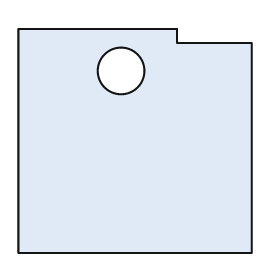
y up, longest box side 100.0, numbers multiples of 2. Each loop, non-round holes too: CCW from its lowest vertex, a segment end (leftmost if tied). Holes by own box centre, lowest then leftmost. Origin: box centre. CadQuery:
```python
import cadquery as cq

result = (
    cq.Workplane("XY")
    .moveTo(-50.0, -48.0)
    .lineTo(50.0, -48.0)
    .lineTo(50.0, 42.0)
    .lineTo(18.0, 42.0)
    .lineTo(18.0, 48.0)
    .lineTo(-50.0, 48.0)
    .close()
    .moveTo(-6.0, 30.0)
    .circle(10.0)
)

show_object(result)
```